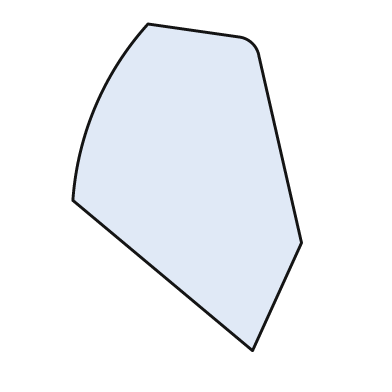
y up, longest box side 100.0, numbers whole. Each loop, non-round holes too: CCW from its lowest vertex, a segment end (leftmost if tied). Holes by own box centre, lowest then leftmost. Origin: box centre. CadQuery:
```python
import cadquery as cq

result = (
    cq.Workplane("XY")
    .moveTo(20.0, -50.0)
    .lineTo(35.0, -17.0)
    .lineTo(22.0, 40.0)
    .threePointArc((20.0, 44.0), (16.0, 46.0))
    .lineTo(-12.0, 50.0)
    .threePointArc((-28.0, 25.0), (-35.0, -4.0))
    .close()
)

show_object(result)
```